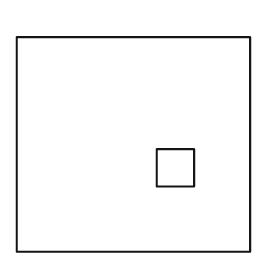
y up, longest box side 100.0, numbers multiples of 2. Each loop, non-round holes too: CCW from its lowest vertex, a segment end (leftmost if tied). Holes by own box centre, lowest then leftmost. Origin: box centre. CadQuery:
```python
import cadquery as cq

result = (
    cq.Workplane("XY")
    .moveTo(-50.0, -46.0)
    .lineTo(50.0, -46.0)
    .lineTo(50.0, 46.0)
    .lineTo(-50.0, 46.0)
    .close()
    .moveTo(10.0, -18.0)
    .lineTo(26.0, -18.0)
    .lineTo(26.0, -2.0)
    .lineTo(10.0, -2.0)
    .close()
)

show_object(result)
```